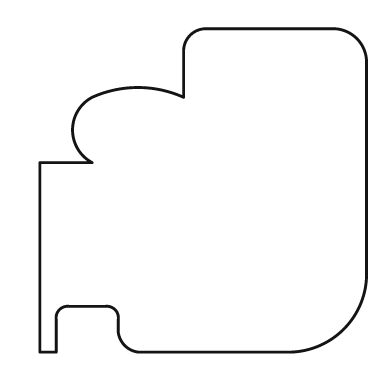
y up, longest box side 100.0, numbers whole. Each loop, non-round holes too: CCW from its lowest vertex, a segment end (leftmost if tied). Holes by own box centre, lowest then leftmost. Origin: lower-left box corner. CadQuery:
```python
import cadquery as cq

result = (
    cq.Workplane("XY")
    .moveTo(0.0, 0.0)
    .lineTo(5.0, 0.0)
    .lineTo(5.0, 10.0)
    .threePointArc((6.0, 13.0), (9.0, 14.0))
    .lineTo(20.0, 14.0)
    .threePointArc((23.0, 13.0), (24.0, 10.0))
    .lineTo(24.0, 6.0)
    .threePointArc((26.0, 2.0), (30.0, 0.0))
    .lineTo(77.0, 0.0)
    .threePointArc((93.0, 7.0), (100.0, 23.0))
    .lineTo(100.0, 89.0)
    .threePointArc((97.0, 96.0), (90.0, 99.0))
    .lineTo(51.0, 99.0)
    .threePointArc((46.0, 97.0), (44.0, 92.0))
    .lineTo(44.0, 78.0)
    .threePointArc((30.0, 81.0), (16.0, 78.0))
    .threePointArc((10.0, 68.0), (16.0, 58.0))
    .lineTo(0.0, 58.0)
    .close()
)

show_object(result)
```